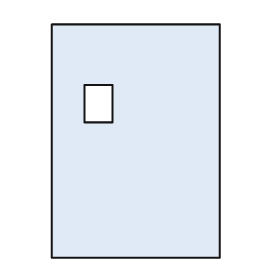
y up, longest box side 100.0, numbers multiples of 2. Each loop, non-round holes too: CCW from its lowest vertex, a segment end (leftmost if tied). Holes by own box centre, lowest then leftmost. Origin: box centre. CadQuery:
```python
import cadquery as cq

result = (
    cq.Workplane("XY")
    .moveTo(-36.0, -50.0)
    .lineTo(36.0, -50.0)
    .lineTo(36.0, 50.0)
    .lineTo(-36.0, 50.0)
    .close()
    .moveTo(-22.0, 8.0)
    .lineTo(-10.0, 8.0)
    .lineTo(-10.0, 24.0)
    .lineTo(-22.0, 24.0)
    .close()
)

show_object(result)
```